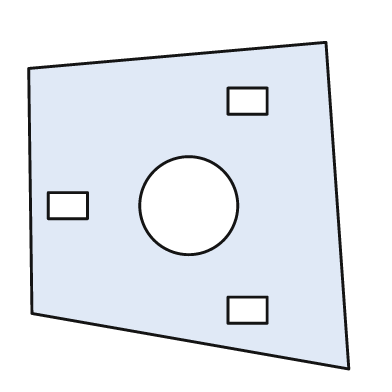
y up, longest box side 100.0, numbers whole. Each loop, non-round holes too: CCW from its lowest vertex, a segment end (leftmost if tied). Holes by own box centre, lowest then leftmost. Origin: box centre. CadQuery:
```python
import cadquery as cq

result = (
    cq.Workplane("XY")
    .moveTo(49.0, -50.0)
    .lineTo(42.0, 50.0)
    .lineTo(-49.0, 42.0)
    .lineTo(-48.0, -33.0)
    .close()
    .moveTo(12.0, -36.0)
    .lineTo(24.0, -36.0)
    .lineTo(24.0, -28.0)
    .lineTo(12.0, -28.0)
    .close()
    .moveTo(-43.0, -4.0)
    .lineTo(-31.0, -4.0)
    .lineTo(-31.0, 4.0)
    .lineTo(-43.0, 4.0)
    .close()
    .moveTo(0.0, 0.0)
    .circle(15.0)
    .moveTo(12.0, 28.0)
    .lineTo(24.0, 28.0)
    .lineTo(24.0, 36.0)
    .lineTo(12.0, 36.0)
    .close()
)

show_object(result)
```